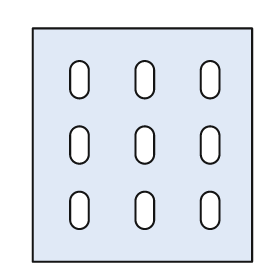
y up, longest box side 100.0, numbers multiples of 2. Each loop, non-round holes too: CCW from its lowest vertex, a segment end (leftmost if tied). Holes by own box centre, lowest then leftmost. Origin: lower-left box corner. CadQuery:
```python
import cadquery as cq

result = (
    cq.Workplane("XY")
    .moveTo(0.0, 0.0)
    .lineTo(94.0, 0.0)
    .lineTo(94.0, 100.0)
    .lineTo(0.0, 100.0)
    .close()
    .moveTo(16.0, 18.0)
    .threePointArc((20.0, 14.0), (24.0, 18.0))
    .lineTo(24.0, 26.0)
    .threePointArc((20.0, 30.0), (16.0, 26.0))
    .close()
    .moveTo(44.0, 18.0)
    .threePointArc((48.0, 14.0), (52.0, 18.0))
    .lineTo(52.0, 26.0)
    .threePointArc((48.0, 30.0), (44.0, 26.0))
    .close()
    .moveTo(72.0, 18.0)
    .threePointArc((76.0, 14.0), (80.0, 18.0))
    .lineTo(80.0, 26.0)
    .threePointArc((76.0, 30.0), (72.0, 26.0))
    .close()
    .moveTo(16.0, 46.0)
    .threePointArc((20.0, 42.0), (24.0, 46.0))
    .lineTo(24.0, 54.0)
    .threePointArc((20.0, 58.0), (16.0, 54.0))
    .close()
    .moveTo(44.0, 46.0)
    .threePointArc((48.0, 42.0), (52.0, 46.0))
    .lineTo(52.0, 54.0)
    .threePointArc((48.0, 58.0), (44.0, 54.0))
    .close()
    .moveTo(72.0, 46.0)
    .threePointArc((76.0, 42.0), (80.0, 46.0))
    .lineTo(80.0, 54.0)
    .threePointArc((76.0, 58.0), (72.0, 54.0))
    .close()
    .moveTo(16.0, 74.0)
    .threePointArc((20.0, 70.0), (24.0, 74.0))
    .lineTo(24.0, 82.0)
    .threePointArc((20.0, 86.0), (16.0, 82.0))
    .close()
    .moveTo(44.0, 74.0)
    .threePointArc((48.0, 70.0), (52.0, 74.0))
    .lineTo(52.0, 82.0)
    .threePointArc((48.0, 86.0), (44.0, 82.0))
    .close()
    .moveTo(72.0, 74.0)
    .threePointArc((76.0, 70.0), (80.0, 74.0))
    .lineTo(80.0, 82.0)
    .threePointArc((76.0, 86.0), (72.0, 82.0))
    .close()
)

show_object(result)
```